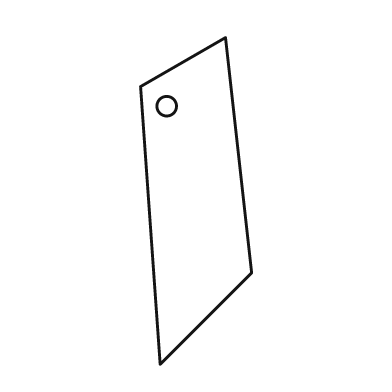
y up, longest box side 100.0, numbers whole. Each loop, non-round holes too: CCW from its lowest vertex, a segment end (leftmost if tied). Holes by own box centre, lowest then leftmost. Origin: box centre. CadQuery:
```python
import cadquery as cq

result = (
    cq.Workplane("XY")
    .moveTo(-11.0, -50.0)
    .lineTo(17.0, -22.0)
    .lineTo(9.0, 50.0)
    .lineTo(-17.0, 35.0)
    .close()
    .moveTo(-9.0, 29.0)
    .circle(3.0)
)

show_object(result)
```